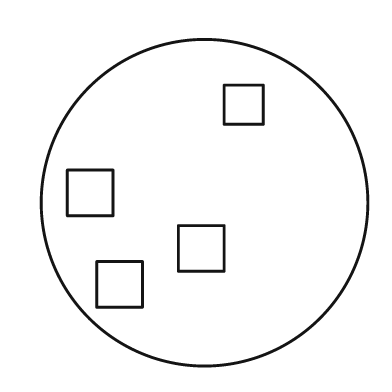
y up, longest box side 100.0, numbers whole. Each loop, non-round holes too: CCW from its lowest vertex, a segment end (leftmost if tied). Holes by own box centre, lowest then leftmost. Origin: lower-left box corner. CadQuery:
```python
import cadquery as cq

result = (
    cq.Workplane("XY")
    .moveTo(50.0, 50.0)
    .circle(50.0)
    .moveTo(17.0, 18.0)
    .lineTo(31.0, 18.0)
    .lineTo(31.0, 32.0)
    .lineTo(17.0, 32.0)
    .close()
    .moveTo(42.0, 29.0)
    .lineTo(56.0, 29.0)
    .lineTo(56.0, 43.0)
    .lineTo(42.0, 43.0)
    .close()
    .moveTo(8.0, 46.0)
    .lineTo(22.0, 46.0)
    .lineTo(22.0, 60.0)
    .lineTo(8.0, 60.0)
    .close()
    .moveTo(56.0, 74.0)
    .lineTo(68.0, 74.0)
    .lineTo(68.0, 86.0)
    .lineTo(56.0, 86.0)
    .close()
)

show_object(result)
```